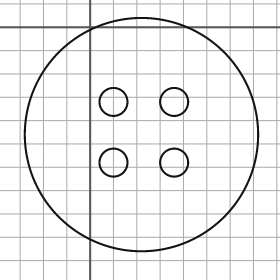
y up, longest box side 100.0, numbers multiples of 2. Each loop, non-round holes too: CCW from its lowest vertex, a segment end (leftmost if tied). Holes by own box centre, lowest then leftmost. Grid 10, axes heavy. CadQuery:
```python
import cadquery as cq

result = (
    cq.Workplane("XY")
    .moveTo(22.0, -46.0)
    .circle(50.0)
    .moveTo(10.0, -58.0)
    .circle(6.0)
    .moveTo(36.0, -58.0)
    .circle(6.0)
    .moveTo(10.0, -32.0)
    .circle(6.0)
    .moveTo(36.0, -32.0)
    .circle(6.0)
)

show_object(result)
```